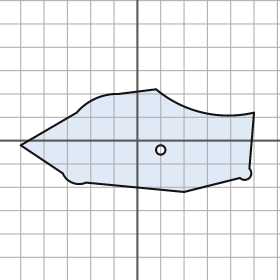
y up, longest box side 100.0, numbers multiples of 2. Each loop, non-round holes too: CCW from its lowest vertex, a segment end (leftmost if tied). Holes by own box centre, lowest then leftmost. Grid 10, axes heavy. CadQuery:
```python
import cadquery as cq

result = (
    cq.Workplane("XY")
    .moveTo(20.0, -22.0)
    .lineTo(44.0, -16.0)
    .threePointArc((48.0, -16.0), (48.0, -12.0))
    .lineTo(50.0, 12.0)
    .threePointArc((28.0, 12.0), (8.0, 22.0))
    .lineTo(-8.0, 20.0)
    .threePointArc((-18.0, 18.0), (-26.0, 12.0))
    .lineTo(-50.0, -2.0)
    .lineTo(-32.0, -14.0)
    .threePointArc((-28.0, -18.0), (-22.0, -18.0))
    .close()
    .moveTo(10.0, -4.0)
    .circle(2.0)
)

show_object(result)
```